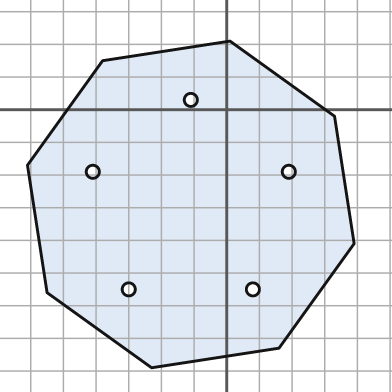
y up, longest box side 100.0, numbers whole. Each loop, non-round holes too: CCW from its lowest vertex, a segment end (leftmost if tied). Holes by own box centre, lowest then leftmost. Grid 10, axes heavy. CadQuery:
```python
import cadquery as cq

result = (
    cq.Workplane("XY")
    .moveTo(-23.0, -79.0)
    .lineTo(16.0, -73.0)
    .lineTo(39.0, -41.0)
    .lineTo(33.0, -2.0)
    .lineTo(1.0, 21.0)
    .lineTo(-38.0, 15.0)
    .lineTo(-61.0, -17.0)
    .lineTo(-55.0, -56.0)
    .close()
    .moveTo(-30.0, -55.0)
    .circle(2.0)
    .moveTo(8.0, -55.0)
    .circle(2.0)
    .moveTo(-41.0, -19.0)
    .circle(2.0)
    .moveTo(19.0, -19.0)
    .circle(2.0)
    .moveTo(-11.0, 3.0)
    .circle(2.0)
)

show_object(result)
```